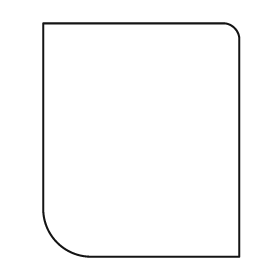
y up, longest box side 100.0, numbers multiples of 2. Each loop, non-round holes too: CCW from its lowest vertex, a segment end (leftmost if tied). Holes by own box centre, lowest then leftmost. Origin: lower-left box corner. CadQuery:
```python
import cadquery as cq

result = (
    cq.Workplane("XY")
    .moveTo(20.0, 0.0)
    .lineTo(84.0, 0.0)
    .lineTo(84.0, 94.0)
    .threePointArc((82.0, 98.0), (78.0, 100.0))
    .lineTo(0.0, 100.0)
    .lineTo(0.0, 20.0)
    .threePointArc((6.0, 6.0), (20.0, 0.0))
    .close()
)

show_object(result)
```